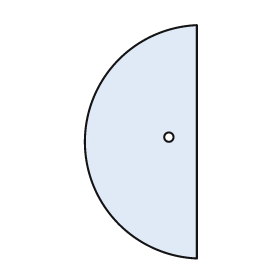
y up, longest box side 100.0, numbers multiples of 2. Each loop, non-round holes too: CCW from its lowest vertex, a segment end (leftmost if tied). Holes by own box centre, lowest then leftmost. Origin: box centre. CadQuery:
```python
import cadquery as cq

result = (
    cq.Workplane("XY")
    .moveTo(24.0, -50.0)
    .lineTo(24.0, 50.0)
    .threePointArc((-24.0, 0.0), (24.0, -50.0))
    .close()
    .moveTo(12.0, 2.0)
    .circle(2.0)
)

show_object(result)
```